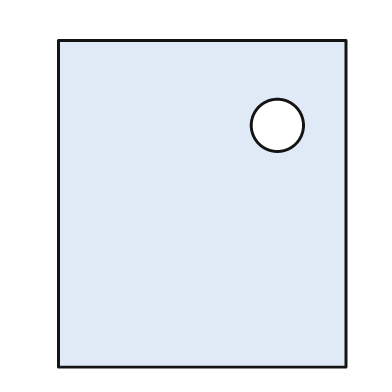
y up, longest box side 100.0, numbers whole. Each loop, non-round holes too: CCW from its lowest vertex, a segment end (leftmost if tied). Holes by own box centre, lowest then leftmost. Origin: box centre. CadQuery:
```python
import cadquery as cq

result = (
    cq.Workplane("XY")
    .moveTo(-44.0, -50.0)
    .lineTo(44.0, -50.0)
    .lineTo(44.0, 50.0)
    .lineTo(-44.0, 50.0)
    .close()
    .moveTo(23.0, 24.0)
    .circle(8.0)
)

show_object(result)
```